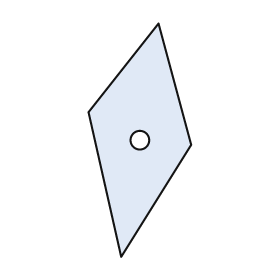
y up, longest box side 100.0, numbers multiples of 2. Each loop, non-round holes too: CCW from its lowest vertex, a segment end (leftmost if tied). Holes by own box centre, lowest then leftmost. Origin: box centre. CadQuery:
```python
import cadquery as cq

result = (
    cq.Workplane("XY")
    .moveTo(-8.0, -50.0)
    .lineTo(22.0, -2.0)
    .lineTo(8.0, 50.0)
    .lineTo(-22.0, 12.0)
    .close()
    .moveTo(0.0, 0.0)
    .circle(4.0)
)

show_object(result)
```